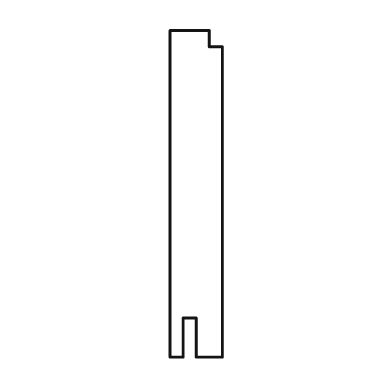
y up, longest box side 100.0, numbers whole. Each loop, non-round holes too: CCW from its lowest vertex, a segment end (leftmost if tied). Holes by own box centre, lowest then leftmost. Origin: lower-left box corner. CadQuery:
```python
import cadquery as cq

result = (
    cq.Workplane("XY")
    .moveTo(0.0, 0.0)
    .lineTo(4.0, 0.0)
    .lineTo(4.0, 12.0)
    .lineTo(8.0, 12.0)
    .lineTo(8.0, 0.0)
    .lineTo(16.0, 0.0)
    .lineTo(16.0, 95.0)
    .lineTo(12.0, 95.0)
    .lineTo(12.0, 100.0)
    .lineTo(0.0, 100.0)
    .close()
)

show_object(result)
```